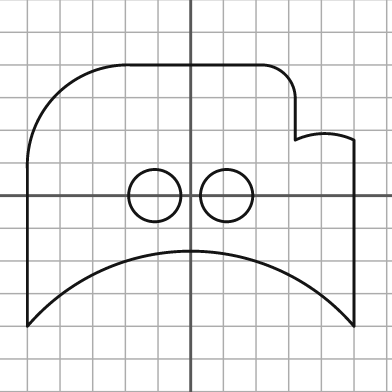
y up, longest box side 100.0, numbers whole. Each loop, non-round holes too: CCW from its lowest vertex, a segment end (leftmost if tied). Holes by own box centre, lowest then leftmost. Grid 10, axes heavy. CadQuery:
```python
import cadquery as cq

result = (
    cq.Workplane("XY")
    .moveTo(-50.0, -40.0)
    .threePointArc((0.0, -17.0), (50.0, -40.0))
    .lineTo(50.0, 17.0)
    .threePointArc((41.0, 19.0), (32.0, 17.0))
    .lineTo(32.0, 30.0)
    .threePointArc((29.0, 37.0), (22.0, 40.0))
    .lineTo(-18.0, 40.0)
    .threePointArc((-41.0, 31.0), (-50.0, 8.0))
    .close()
    .moveTo(-11.0, 0.0)
    .circle(8.0)
    .moveTo(11.0, 0.0)
    .circle(8.0)
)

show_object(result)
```